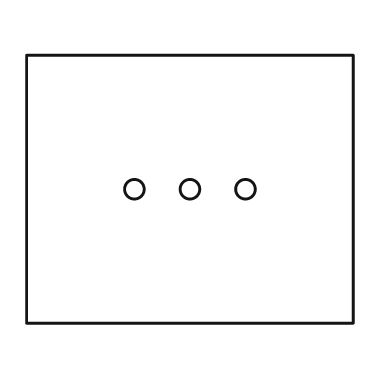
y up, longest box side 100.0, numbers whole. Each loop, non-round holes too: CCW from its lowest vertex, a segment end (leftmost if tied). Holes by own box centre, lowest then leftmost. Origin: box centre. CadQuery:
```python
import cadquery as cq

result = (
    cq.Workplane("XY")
    .moveTo(-50.0, -41.0)
    .lineTo(50.0, -41.0)
    .lineTo(50.0, 41.0)
    .lineTo(-50.0, 41.0)
    .close()
    .moveTo(-17.0, 0.0)
    .circle(3.0)
    .moveTo(0.0, 0.0)
    .circle(3.0)
    .moveTo(17.0, 0.0)
    .circle(3.0)
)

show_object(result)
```